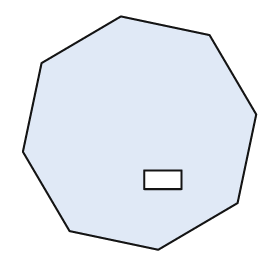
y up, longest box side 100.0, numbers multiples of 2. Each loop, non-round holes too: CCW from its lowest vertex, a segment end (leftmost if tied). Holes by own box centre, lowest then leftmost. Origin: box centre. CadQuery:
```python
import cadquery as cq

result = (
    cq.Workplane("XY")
    .moveTo(8.0, -50.0)
    .lineTo(42.0, -30.0)
    .lineTo(50.0, 8.0)
    .lineTo(30.0, 42.0)
    .lineTo(-8.0, 50.0)
    .lineTo(-42.0, 30.0)
    .lineTo(-50.0, -8.0)
    .lineTo(-30.0, -42.0)
    .close()
    .moveTo(2.0, -24.0)
    .lineTo(18.0, -24.0)
    .lineTo(18.0, -16.0)
    .lineTo(2.0, -16.0)
    .close()
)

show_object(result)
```